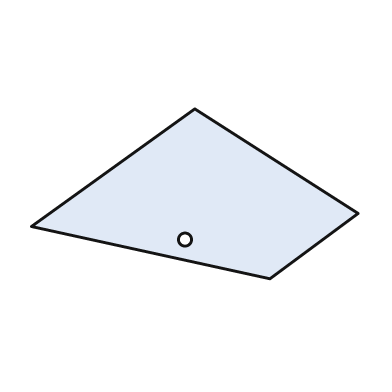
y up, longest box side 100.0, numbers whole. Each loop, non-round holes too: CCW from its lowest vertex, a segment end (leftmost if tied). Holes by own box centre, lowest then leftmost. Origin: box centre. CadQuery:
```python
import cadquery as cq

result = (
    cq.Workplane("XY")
    .moveTo(23.0, -26.0)
    .lineTo(50.0, -6.0)
    .lineTo(0.0, 26.0)
    .lineTo(-50.0, -10.0)
    .close()
    .moveTo(-3.0, -14.0)
    .circle(2.0)
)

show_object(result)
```